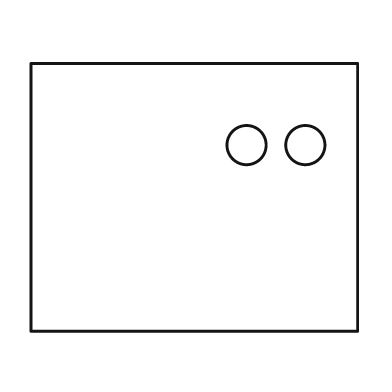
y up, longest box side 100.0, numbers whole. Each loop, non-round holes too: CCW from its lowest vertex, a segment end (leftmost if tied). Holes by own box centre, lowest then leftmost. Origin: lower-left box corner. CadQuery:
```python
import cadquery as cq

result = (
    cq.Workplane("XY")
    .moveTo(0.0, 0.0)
    .lineTo(100.0, 0.0)
    .lineTo(100.0, 82.0)
    .lineTo(0.0, 82.0)
    .close()
    .moveTo(66.0, 57.0)
    .circle(6.0)
    .moveTo(84.0, 57.0)
    .circle(6.0)
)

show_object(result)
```